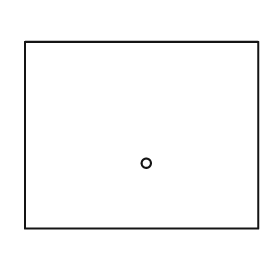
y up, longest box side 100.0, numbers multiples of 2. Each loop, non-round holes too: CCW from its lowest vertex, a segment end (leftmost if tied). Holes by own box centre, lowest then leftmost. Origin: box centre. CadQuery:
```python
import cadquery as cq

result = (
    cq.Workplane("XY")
    .moveTo(-50.0, -40.0)
    .lineTo(50.0, -40.0)
    .lineTo(50.0, 40.0)
    .lineTo(-50.0, 40.0)
    .close()
    .moveTo(2.0, -12.0)
    .circle(2.0)
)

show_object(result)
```